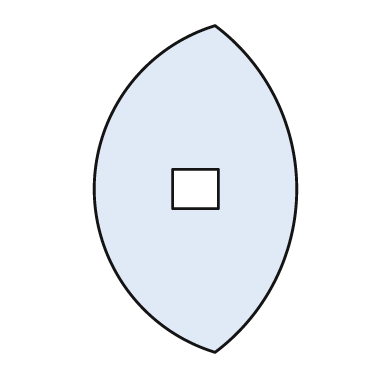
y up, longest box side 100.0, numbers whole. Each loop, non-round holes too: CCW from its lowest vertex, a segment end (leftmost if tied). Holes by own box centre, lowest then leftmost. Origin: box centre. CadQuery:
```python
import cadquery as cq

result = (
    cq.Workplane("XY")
    .moveTo(6.0, -50.0)
    .threePointArc((31.0, 0.0), (6.0, 50.0))
    .threePointArc((-31.0, 0.0), (6.0, -50.0))
    .close()
    .moveTo(-7.0, -6.0)
    .lineTo(7.0, -6.0)
    .lineTo(7.0, 6.0)
    .lineTo(-7.0, 6.0)
    .close()
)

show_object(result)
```